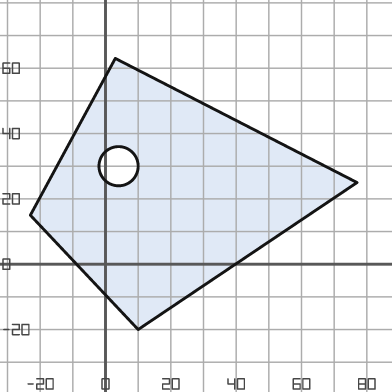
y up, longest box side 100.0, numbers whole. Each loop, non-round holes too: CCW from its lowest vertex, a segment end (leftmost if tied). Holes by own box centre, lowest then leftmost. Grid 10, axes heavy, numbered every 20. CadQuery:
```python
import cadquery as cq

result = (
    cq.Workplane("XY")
    .moveTo(10.0, -20.0)
    .lineTo(77.0, 25.0)
    .lineTo(3.0, 63.0)
    .lineTo(-23.0, 15.0)
    .close()
    .moveTo(4.0, 30.0)
    .circle(6.0)
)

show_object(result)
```